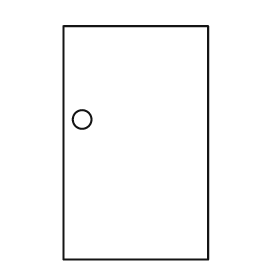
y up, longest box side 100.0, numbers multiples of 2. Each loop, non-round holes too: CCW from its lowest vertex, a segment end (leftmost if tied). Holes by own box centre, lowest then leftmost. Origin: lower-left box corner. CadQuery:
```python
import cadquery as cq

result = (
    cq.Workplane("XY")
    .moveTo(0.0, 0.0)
    .lineTo(62.0, 0.0)
    .lineTo(62.0, 100.0)
    .lineTo(0.0, 100.0)
    .close()
    .moveTo(8.0, 60.0)
    .circle(4.0)
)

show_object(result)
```